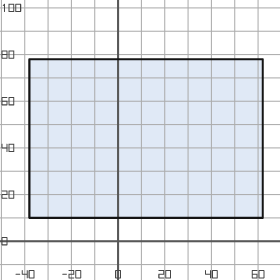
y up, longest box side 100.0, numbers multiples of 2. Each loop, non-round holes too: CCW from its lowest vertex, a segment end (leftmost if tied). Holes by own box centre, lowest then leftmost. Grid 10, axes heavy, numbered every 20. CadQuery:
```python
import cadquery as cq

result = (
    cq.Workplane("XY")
    .moveTo(-38.0, 10.0)
    .lineTo(62.0, 10.0)
    .lineTo(62.0, 78.0)
    .lineTo(-38.0, 78.0)
    .close()
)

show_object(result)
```